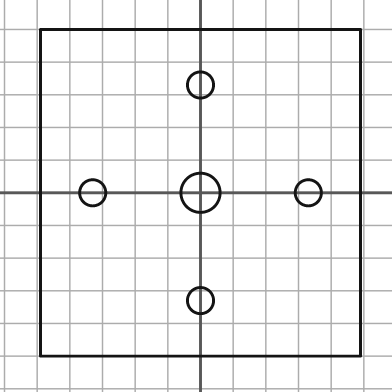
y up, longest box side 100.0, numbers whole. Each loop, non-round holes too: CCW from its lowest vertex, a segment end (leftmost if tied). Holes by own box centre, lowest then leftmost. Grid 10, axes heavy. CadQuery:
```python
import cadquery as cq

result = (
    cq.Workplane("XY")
    .moveTo(-49.0, -50.0)
    .lineTo(49.0, -50.0)
    .lineTo(49.0, 50.0)
    .lineTo(-49.0, 50.0)
    .close()
    .moveTo(0.0, -33.0)
    .circle(4.0)
    .moveTo(-33.0, 0.0)
    .circle(4.0)
    .moveTo(0.0, 0.0)
    .circle(6.0)
    .moveTo(33.0, 0.0)
    .circle(4.0)
    .moveTo(0.0, 33.0)
    .circle(4.0)
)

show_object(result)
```